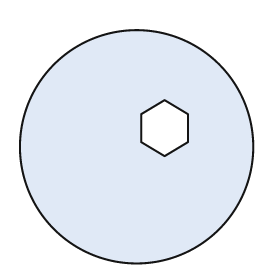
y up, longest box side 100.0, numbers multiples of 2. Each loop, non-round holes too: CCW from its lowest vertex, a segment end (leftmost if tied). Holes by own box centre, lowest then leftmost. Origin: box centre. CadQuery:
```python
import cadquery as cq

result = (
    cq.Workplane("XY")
    .moveTo(0.0, 0.0)
    .circle(50.0)
    .moveTo(12.0, -4.0)
    .lineTo(22.0, 2.0)
    .lineTo(22.0, 14.0)
    .lineTo(12.0, 20.0)
    .lineTo(2.0, 14.0)
    .lineTo(2.0, 2.0)
    .close()
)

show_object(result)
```